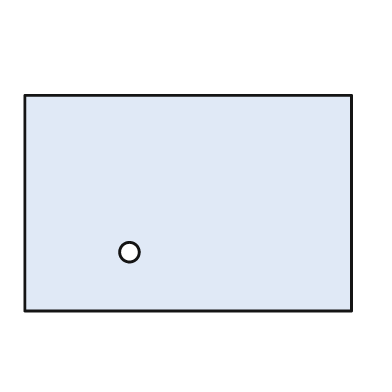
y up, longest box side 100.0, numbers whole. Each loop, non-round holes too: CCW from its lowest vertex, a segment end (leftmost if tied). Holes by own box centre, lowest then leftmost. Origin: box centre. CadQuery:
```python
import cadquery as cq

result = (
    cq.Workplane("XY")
    .moveTo(-50.0, -33.0)
    .lineTo(50.0, -33.0)
    .lineTo(50.0, 33.0)
    .lineTo(-50.0, 33.0)
    .close()
    .moveTo(-18.0, -15.0)
    .circle(3.0)
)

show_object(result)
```